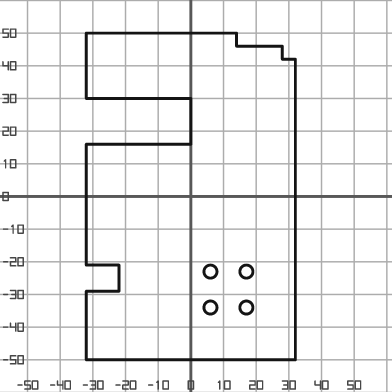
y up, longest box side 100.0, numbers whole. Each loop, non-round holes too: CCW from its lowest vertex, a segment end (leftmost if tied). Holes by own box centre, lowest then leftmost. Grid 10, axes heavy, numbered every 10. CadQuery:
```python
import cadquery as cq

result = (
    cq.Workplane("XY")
    .moveTo(-32.0, -50.0)
    .lineTo(32.0, -50.0)
    .lineTo(32.0, 42.0)
    .lineTo(28.0, 42.0)
    .lineTo(28.0, 46.0)
    .lineTo(14.0, 46.0)
    .lineTo(14.0, 50.0)
    .lineTo(-32.0, 50.0)
    .lineTo(-32.0, 30.0)
    .lineTo(0.0, 30.0)
    .lineTo(0.0, 16.0)
    .lineTo(-32.0, 16.0)
    .lineTo(-32.0, -21.0)
    .lineTo(-22.0, -21.0)
    .lineTo(-22.0, -29.0)
    .lineTo(-32.0, -29.0)
    .close()
    .moveTo(6.0, -34.0)
    .circle(2.0)
    .moveTo(17.0, -34.0)
    .circle(2.0)
    .moveTo(6.0, -23.0)
    .circle(2.0)
    .moveTo(17.0, -23.0)
    .circle(2.0)
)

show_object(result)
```